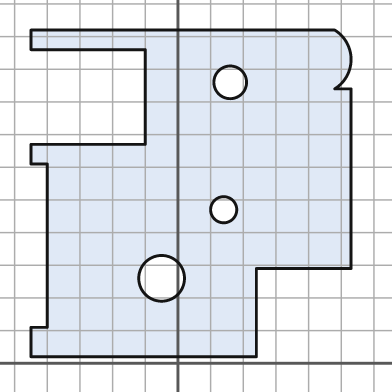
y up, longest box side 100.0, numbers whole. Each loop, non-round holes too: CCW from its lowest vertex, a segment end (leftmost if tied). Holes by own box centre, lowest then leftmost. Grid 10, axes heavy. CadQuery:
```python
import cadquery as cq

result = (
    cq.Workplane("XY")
    .moveTo(-45.0, 2.0)
    .lineTo(24.0, 2.0)
    .lineTo(24.0, 29.0)
    .lineTo(53.0, 29.0)
    .lineTo(53.0, 84.0)
    .lineTo(48.0, 84.0)
    .threePointArc((53.0, 93.0), (48.0, 102.0))
    .lineTo(-45.0, 102.0)
    .lineTo(-45.0, 96.0)
    .lineTo(-10.0, 96.0)
    .lineTo(-10.0, 67.0)
    .lineTo(-45.0, 67.0)
    .lineTo(-45.0, 61.0)
    .lineTo(-40.0, 61.0)
    .lineTo(-40.0, 11.0)
    .lineTo(-45.0, 11.0)
    .close()
    .moveTo(-5.0, 26.0)
    .circle(7.0)
    .moveTo(14.0, 47.0)
    .circle(4.0)
    .moveTo(16.0, 86.0)
    .circle(5.0)
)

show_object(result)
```